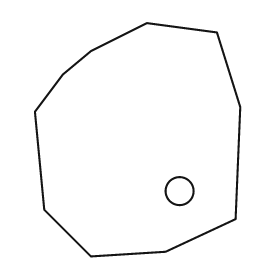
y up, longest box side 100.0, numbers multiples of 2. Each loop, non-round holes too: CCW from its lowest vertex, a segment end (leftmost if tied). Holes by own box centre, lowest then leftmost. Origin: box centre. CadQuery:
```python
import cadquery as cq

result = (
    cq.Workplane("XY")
    .moveTo(-20.0, -50.0)
    .lineTo(12.0, -48.0)
    .lineTo(42.0, -34.0)
    .lineTo(44.0, 14.0)
    .lineTo(34.0, 46.0)
    .lineTo(4.0, 50.0)
    .lineTo(-20.0, 38.0)
    .lineTo(-32.0, 28.0)
    .lineTo(-44.0, 12.0)
    .lineTo(-40.0, -30.0)
    .close()
    .moveTo(18.0, -22.0)
    .circle(6.0)
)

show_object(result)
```